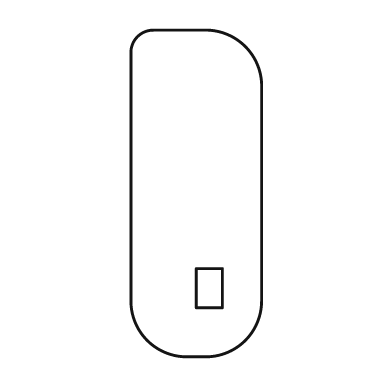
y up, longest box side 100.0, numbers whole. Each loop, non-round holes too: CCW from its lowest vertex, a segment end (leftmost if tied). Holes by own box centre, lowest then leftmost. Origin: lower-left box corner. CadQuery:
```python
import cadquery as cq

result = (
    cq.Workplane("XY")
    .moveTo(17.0, 0.0)
    .lineTo(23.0, 0.0)
    .threePointArc((35.0, 5.0), (40.0, 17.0))
    .lineTo(40.0, 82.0)
    .threePointArc((35.0, 95.0), (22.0, 100.0))
    .lineTo(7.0, 100.0)
    .threePointArc((2.0, 98.0), (0.0, 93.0))
    .lineTo(0.0, 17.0)
    .threePointArc((5.0, 5.0), (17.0, 0.0))
    .close()
    .moveTo(20.0, 15.0)
    .lineTo(28.0, 15.0)
    .lineTo(28.0, 27.0)
    .lineTo(20.0, 27.0)
    .close()
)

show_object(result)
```